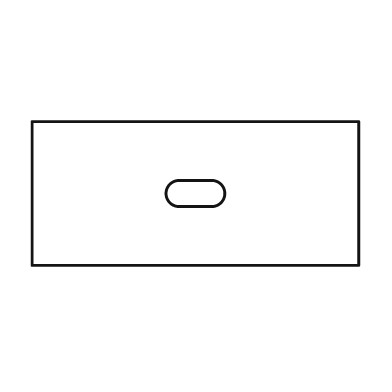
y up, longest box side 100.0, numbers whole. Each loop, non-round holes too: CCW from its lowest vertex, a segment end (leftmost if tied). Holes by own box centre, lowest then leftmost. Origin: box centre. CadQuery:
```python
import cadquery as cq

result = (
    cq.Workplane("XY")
    .moveTo(-50.0, -22.0)
    .lineTo(50.0, -22.0)
    .lineTo(50.0, 22.0)
    .lineTo(-50.0, 22.0)
    .close()
    .moveTo(-5.0, -4.0)
    .lineTo(5.0, -4.0)
    .threePointArc((9.0, 0.0), (5.0, 4.0))
    .lineTo(-5.0, 4.0)
    .threePointArc((-9.0, 0.0), (-5.0, -4.0))
    .close()
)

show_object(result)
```